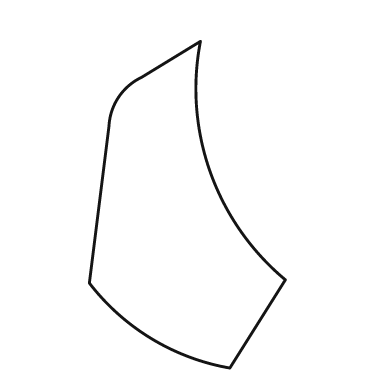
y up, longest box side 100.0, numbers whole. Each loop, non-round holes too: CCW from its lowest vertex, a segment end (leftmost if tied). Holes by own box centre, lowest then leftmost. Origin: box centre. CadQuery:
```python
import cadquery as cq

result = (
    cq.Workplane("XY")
    .moveTo(13.0, -50.0)
    .lineTo(30.0, -23.0)
    .threePointArc((7.0, 10.0), (4.0, 50.0))
    .lineTo(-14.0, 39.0)
    .threePointArc((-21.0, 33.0), (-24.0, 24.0))
    .lineTo(-30.0, -24.0)
    .threePointArc((-11.0, -41.0), (13.0, -50.0))
    .close()
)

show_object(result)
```